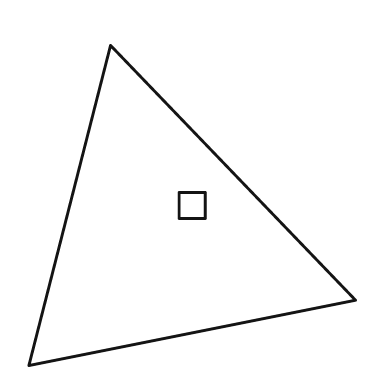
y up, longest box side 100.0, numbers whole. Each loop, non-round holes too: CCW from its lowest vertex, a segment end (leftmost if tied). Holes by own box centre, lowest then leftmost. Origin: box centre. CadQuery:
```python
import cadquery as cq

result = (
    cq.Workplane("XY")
    .moveTo(-50.0, -49.0)
    .lineTo(50.0, -29.0)
    .lineTo(-25.0, 49.0)
    .close()
    .moveTo(-4.0, -4.0)
    .lineTo(4.0, -4.0)
    .lineTo(4.0, 4.0)
    .lineTo(-4.0, 4.0)
    .close()
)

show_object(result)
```